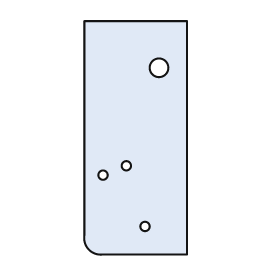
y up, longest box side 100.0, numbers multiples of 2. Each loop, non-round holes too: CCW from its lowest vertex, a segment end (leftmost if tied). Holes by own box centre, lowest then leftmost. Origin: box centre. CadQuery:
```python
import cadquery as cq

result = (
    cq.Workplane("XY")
    .moveTo(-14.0, -50.0)
    .lineTo(22.0, -50.0)
    .lineTo(22.0, 50.0)
    .lineTo(-22.0, 50.0)
    .lineTo(-22.0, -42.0)
    .threePointArc((-20.0, -48.0), (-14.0, -50.0))
    .close()
    .moveTo(4.0, -38.0)
    .circle(2.0)
    .moveTo(-14.0, -16.0)
    .circle(2.0)
    .moveTo(-4.0, -12.0)
    .circle(2.0)
    .moveTo(10.0, 30.0)
    .circle(4.0)
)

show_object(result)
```